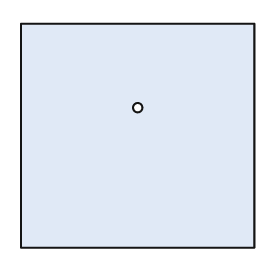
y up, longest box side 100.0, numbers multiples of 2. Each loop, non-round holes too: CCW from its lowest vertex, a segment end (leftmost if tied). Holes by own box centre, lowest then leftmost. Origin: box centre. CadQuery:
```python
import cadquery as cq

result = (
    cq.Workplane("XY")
    .moveTo(-50.0, -48.0)
    .lineTo(50.0, -48.0)
    .lineTo(50.0, 48.0)
    .lineTo(-50.0, 48.0)
    .close()
    .moveTo(0.0, 12.0)
    .circle(2.0)
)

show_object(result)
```